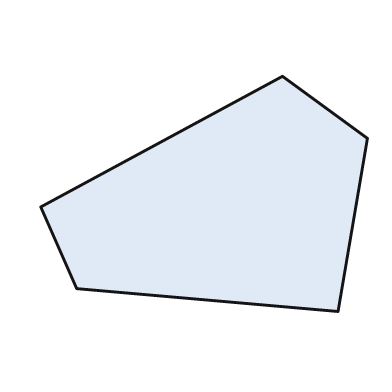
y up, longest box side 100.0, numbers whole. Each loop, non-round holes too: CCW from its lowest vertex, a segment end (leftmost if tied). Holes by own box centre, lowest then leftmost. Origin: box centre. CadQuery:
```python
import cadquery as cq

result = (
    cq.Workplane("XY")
    .moveTo(41.0, -36.0)
    .lineTo(50.0, 17.0)
    .lineTo(24.0, 36.0)
    .lineTo(-50.0, -4.0)
    .lineTo(-39.0, -29.0)
    .close()
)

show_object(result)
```